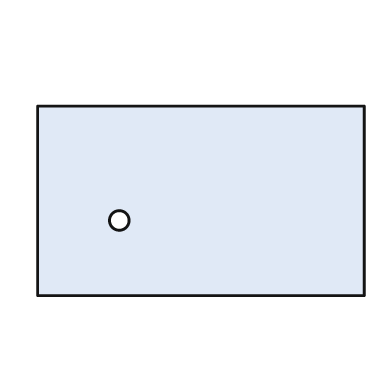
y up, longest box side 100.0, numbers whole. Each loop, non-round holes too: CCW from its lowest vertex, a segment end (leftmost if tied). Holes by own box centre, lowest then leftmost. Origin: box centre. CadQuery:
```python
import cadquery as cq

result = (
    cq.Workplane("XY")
    .moveTo(-50.0, -29.0)
    .lineTo(50.0, -29.0)
    .lineTo(50.0, 29.0)
    .lineTo(-50.0, 29.0)
    .close()
    .moveTo(-25.0, -6.0)
    .circle(3.0)
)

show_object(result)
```